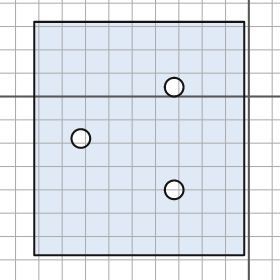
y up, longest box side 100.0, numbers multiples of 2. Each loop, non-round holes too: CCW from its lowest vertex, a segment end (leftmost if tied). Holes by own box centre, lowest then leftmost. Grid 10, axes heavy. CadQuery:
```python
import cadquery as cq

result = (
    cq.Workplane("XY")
    .moveTo(-92.0, -68.0)
    .lineTo(-2.0, -68.0)
    .lineTo(-2.0, 32.0)
    .lineTo(-92.0, 32.0)
    .close()
    .moveTo(-32.0, -40.0)
    .circle(4.0)
    .moveTo(-72.0, -18.0)
    .circle(4.0)
    .moveTo(-32.0, 4.0)
    .circle(4.0)
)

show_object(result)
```